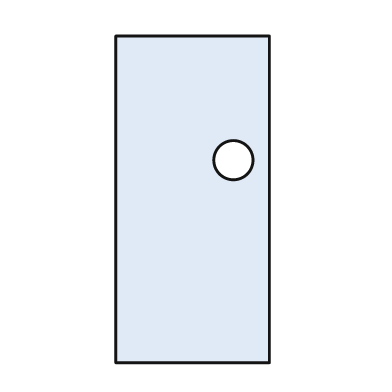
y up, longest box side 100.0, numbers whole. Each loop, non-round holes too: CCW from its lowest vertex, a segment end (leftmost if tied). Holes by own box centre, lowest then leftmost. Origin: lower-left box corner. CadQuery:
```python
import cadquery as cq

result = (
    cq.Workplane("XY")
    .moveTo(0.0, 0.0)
    .lineTo(47.0, 0.0)
    .lineTo(47.0, 100.0)
    .lineTo(0.0, 100.0)
    .close()
    .moveTo(36.0, 62.0)
    .circle(6.0)
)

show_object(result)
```